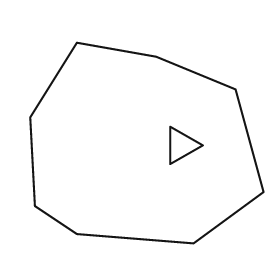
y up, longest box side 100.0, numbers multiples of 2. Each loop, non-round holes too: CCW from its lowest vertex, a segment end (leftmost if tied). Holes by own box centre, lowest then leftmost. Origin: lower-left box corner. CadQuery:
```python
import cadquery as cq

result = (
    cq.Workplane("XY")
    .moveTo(70.0, 0.0)
    .lineTo(100.0, 22.0)
    .lineTo(88.0, 66.0)
    .lineTo(54.0, 80.0)
    .lineTo(20.0, 86.0)
    .lineTo(0.0, 54.0)
    .lineTo(2.0, 16.0)
    .lineTo(20.0, 4.0)
    .close()
    .moveTo(60.0, 34.0)
    .lineTo(74.0, 42.0)
    .lineTo(60.0, 50.0)
    .close()
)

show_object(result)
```